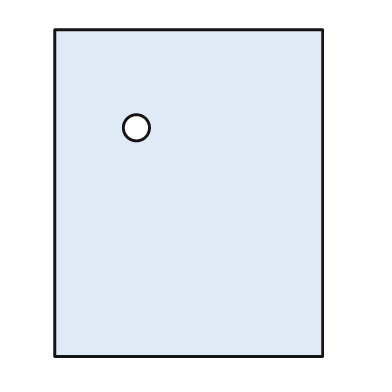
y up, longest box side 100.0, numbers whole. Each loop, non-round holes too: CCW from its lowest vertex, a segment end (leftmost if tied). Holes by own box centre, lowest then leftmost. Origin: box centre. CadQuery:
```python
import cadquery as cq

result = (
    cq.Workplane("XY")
    .moveTo(-41.0, -50.0)
    .lineTo(41.0, -50.0)
    .lineTo(41.0, 50.0)
    .lineTo(-41.0, 50.0)
    .close()
    .moveTo(-16.0, 20.0)
    .circle(4.0)
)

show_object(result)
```